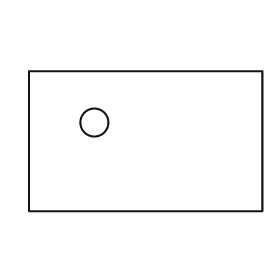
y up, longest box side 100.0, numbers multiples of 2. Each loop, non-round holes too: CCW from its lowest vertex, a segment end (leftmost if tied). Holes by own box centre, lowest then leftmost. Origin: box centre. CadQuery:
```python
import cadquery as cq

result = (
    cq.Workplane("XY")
    .moveTo(-50.0, -30.0)
    .lineTo(50.0, -30.0)
    .lineTo(50.0, 30.0)
    .lineTo(-50.0, 30.0)
    .close()
    .moveTo(-22.0, 8.0)
    .circle(6.0)
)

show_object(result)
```